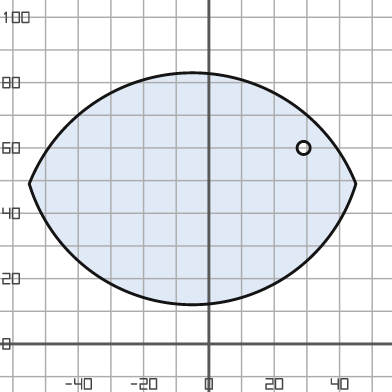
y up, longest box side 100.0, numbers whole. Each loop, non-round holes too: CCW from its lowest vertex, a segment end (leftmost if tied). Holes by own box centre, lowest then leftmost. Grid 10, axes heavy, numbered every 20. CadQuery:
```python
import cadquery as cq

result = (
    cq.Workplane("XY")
    .moveTo(-55.0, 49.0)
    .threePointArc((-5.0, 12.0), (45.0, 49.0))
    .threePointArc((-5.0, 83.0), (-55.0, 49.0))
    .close()
    .moveTo(29.0, 60.0)
    .circle(2.0)
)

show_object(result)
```